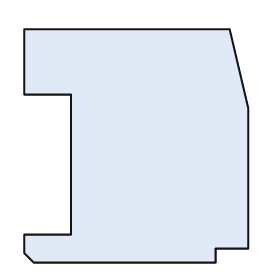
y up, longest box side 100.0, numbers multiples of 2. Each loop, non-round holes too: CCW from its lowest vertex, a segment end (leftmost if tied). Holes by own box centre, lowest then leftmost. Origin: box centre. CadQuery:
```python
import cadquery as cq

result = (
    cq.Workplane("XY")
    .moveTo(-44.0, -50.0)
    .lineTo(34.0, -50.0)
    .lineTo(34.0, -44.0)
    .lineTo(48.0, -44.0)
    .lineTo(48.0, 16.0)
    .lineTo(40.0, 50.0)
    .lineTo(-48.0, 50.0)
    .lineTo(-48.0, 22.0)
    .lineTo(-28.0, 22.0)
    .lineTo(-28.0, -38.0)
    .lineTo(-48.0, -38.0)
    .lineTo(-48.0, -46.0)
    .close()
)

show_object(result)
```